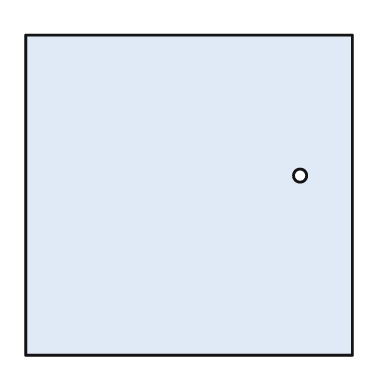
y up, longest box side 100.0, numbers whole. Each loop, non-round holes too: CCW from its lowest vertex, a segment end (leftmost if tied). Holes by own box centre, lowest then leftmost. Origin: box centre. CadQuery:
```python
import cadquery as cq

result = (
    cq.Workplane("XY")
    .moveTo(-50.0, -49.0)
    .lineTo(50.0, -49.0)
    .lineTo(50.0, 49.0)
    .lineTo(-50.0, 49.0)
    .close()
    .moveTo(34.0, 6.0)
    .circle(2.0)
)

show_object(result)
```